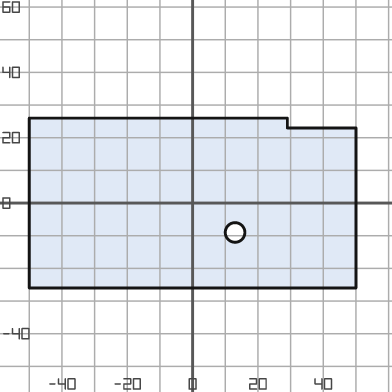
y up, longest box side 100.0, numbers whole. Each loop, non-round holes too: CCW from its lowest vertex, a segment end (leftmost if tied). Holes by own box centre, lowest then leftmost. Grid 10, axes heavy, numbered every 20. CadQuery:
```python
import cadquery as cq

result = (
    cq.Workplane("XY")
    .moveTo(-50.0, -26.0)
    .lineTo(50.0, -26.0)
    .lineTo(50.0, 23.0)
    .lineTo(29.0, 23.0)
    .lineTo(29.0, 26.0)
    .lineTo(-50.0, 26.0)
    .close()
    .moveTo(13.0, -9.0)
    .circle(3.0)
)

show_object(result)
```